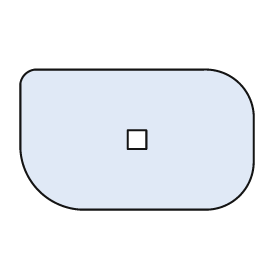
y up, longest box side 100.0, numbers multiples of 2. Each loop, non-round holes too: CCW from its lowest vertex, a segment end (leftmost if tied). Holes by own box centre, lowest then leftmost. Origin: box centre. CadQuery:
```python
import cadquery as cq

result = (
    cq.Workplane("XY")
    .moveTo(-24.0, -30.0)
    .lineTo(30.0, -30.0)
    .threePointArc((44.0, -24.0), (50.0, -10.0))
    .lineTo(50.0, 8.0)
    .threePointArc((44.0, 24.0), (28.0, 30.0))
    .lineTo(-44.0, 30.0)
    .threePointArc((-48.0, 28.0), (-50.0, 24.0))
    .lineTo(-50.0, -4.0)
    .threePointArc((-42.0, -22.0), (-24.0, -30.0))
    .close()
    .moveTo(-4.0, -4.0)
    .lineTo(4.0, -4.0)
    .lineTo(4.0, 4.0)
    .lineTo(-4.0, 4.0)
    .close()
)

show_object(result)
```